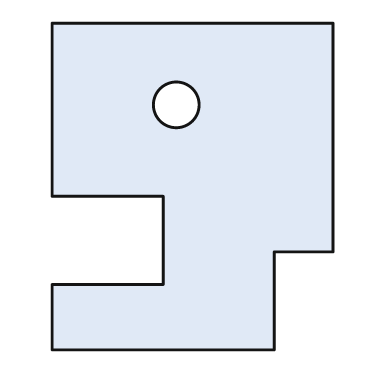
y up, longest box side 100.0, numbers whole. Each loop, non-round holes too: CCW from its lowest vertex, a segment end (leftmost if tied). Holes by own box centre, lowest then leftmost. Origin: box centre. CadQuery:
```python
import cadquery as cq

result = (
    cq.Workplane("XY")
    .moveTo(-43.0, -50.0)
    .lineTo(25.0, -50.0)
    .lineTo(25.0, -20.0)
    .lineTo(43.0, -20.0)
    .lineTo(43.0, 50.0)
    .lineTo(-43.0, 50.0)
    .lineTo(-43.0, -3.0)
    .lineTo(-9.0, -3.0)
    .lineTo(-9.0, -30.0)
    .lineTo(-43.0, -30.0)
    .close()
    .moveTo(-5.0, 25.0)
    .circle(7.0)
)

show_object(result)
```